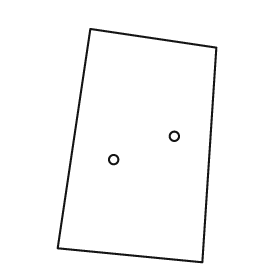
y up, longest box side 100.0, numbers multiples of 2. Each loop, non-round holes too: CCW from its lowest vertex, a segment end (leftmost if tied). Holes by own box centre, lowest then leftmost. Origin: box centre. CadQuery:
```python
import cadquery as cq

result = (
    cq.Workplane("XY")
    .moveTo(28.0, -50.0)
    .lineTo(34.0, 42.0)
    .lineTo(-20.0, 50.0)
    .lineTo(-34.0, -44.0)
    .close()
    .moveTo(-10.0, -6.0)
    .circle(2.0)
    .moveTo(16.0, 4.0)
    .circle(2.0)
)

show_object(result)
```